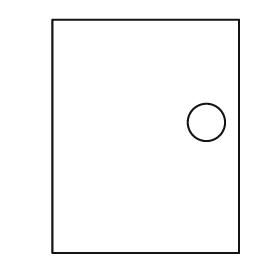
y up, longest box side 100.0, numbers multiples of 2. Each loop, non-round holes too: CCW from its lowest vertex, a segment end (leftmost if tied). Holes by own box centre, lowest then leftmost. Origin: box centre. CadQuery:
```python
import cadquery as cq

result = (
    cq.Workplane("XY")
    .moveTo(-40.0, -50.0)
    .lineTo(40.0, -50.0)
    .lineTo(40.0, 50.0)
    .lineTo(-40.0, 50.0)
    .close()
    .moveTo(26.0, 6.0)
    .circle(8.0)
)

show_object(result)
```